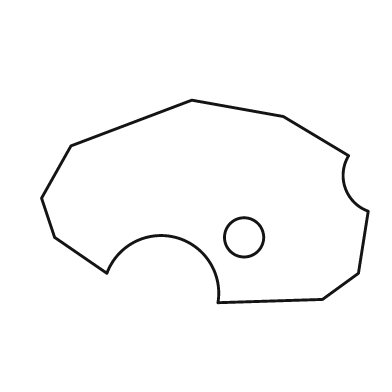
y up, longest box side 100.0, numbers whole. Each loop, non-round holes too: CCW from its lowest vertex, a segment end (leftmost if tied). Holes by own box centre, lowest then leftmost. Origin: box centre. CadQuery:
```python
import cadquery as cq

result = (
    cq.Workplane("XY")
    .moveTo(4.0, -31.0)
    .lineTo(36.0, -30.0)
    .lineTo(47.0, -22.0)
    .lineTo(50.0, -3.0)
    .threePointArc((43.0, 4.0), (44.0, 14.0))
    .lineTo(24.0, 26.0)
    .lineTo(-4.0, 31.0)
    .lineTo(-41.0, 17.0)
    .lineTo(-50.0, 1.0)
    .lineTo(-46.0, -11.0)
    .lineTo(-30.0, -22.0)
    .threePointArc((-9.0, -11.0), (4.0, -31.0))
    .close()
    .moveTo(12.0, -11.0)
    .circle(6.0)
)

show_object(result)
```